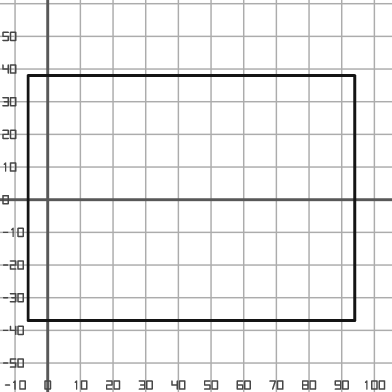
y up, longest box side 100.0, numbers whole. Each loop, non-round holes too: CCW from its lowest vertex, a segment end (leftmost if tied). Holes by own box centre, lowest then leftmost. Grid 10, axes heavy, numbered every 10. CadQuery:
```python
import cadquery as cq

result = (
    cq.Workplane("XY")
    .moveTo(-6.0, -37.0)
    .lineTo(94.0, -37.0)
    .lineTo(94.0, 38.0)
    .lineTo(-6.0, 38.0)
    .close()
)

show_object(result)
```